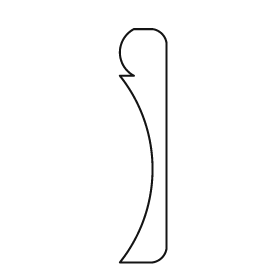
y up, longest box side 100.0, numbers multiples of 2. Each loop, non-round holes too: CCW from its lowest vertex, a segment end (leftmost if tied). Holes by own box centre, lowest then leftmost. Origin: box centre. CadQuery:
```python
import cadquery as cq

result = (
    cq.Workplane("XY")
    .moveTo(-10.0, -50.0)
    .lineTo(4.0, -50.0)
    .threePointArc((8.0, -48.0), (10.0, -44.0))
    .lineTo(10.0, 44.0)
    .threePointArc((8.0, 48.0), (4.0, 50.0))
    .lineTo(-4.0, 50.0)
    .threePointArc((-10.0, 40.0), (-4.0, 30.0))
    .lineTo(-10.0, 30.0)
    .threePointArc((4.0, -10.0), (-10.0, -50.0))
    .close()
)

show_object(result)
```